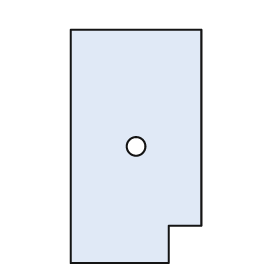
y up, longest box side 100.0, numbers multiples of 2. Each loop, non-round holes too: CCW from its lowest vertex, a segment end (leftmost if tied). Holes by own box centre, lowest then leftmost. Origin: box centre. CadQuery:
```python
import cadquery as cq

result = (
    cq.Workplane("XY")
    .moveTo(-28.0, -50.0)
    .lineTo(14.0, -50.0)
    .lineTo(14.0, -34.0)
    .lineTo(28.0, -34.0)
    .lineTo(28.0, 50.0)
    .lineTo(-28.0, 50.0)
    .close()
    .moveTo(0.0, 0.0)
    .circle(4.0)
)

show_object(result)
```